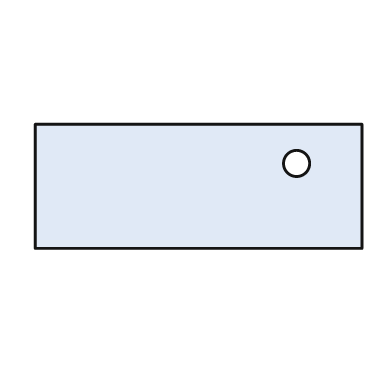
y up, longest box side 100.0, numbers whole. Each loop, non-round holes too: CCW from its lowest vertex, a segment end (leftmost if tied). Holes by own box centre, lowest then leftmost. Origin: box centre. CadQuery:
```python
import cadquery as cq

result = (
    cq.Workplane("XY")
    .moveTo(-50.0, -19.0)
    .lineTo(50.0, -19.0)
    .lineTo(50.0, 19.0)
    .lineTo(-50.0, 19.0)
    .close()
    .moveTo(30.0, 7.0)
    .circle(4.0)
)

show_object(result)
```